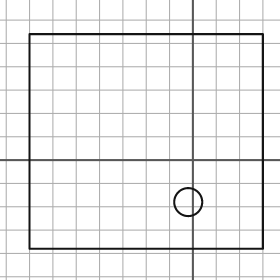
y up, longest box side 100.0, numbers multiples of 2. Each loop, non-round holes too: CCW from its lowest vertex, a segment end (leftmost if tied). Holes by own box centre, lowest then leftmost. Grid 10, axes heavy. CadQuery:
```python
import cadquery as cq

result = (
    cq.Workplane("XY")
    .moveTo(-70.0, -38.0)
    .lineTo(30.0, -38.0)
    .lineTo(30.0, 54.0)
    .lineTo(-70.0, 54.0)
    .close()
    .moveTo(-2.0, -18.0)
    .circle(6.0)
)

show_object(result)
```